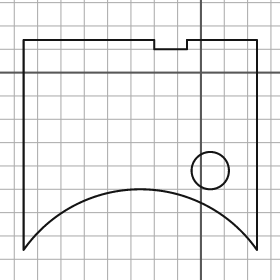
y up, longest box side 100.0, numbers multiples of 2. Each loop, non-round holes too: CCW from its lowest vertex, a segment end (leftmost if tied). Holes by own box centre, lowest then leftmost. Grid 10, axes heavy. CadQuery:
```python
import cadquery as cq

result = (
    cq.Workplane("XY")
    .moveTo(-76.0, -76.0)
    .threePointArc((-26.0, -50.0), (24.0, -76.0))
    .lineTo(24.0, 14.0)
    .lineTo(-6.0, 14.0)
    .lineTo(-6.0, 10.0)
    .lineTo(-20.0, 10.0)
    .lineTo(-20.0, 14.0)
    .lineTo(-76.0, 14.0)
    .close()
    .moveTo(4.0, -42.0)
    .circle(8.0)
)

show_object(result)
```